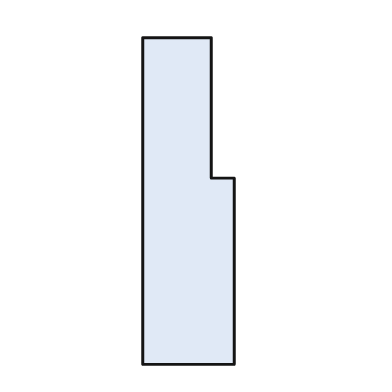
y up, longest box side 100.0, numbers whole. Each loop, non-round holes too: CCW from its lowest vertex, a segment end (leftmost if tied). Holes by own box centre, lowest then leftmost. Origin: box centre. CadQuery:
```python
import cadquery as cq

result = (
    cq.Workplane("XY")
    .moveTo(-14.0, -50.0)
    .lineTo(14.0, -50.0)
    .lineTo(14.0, 7.0)
    .lineTo(7.0, 7.0)
    .lineTo(7.0, 50.0)
    .lineTo(-14.0, 50.0)
    .close()
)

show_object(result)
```